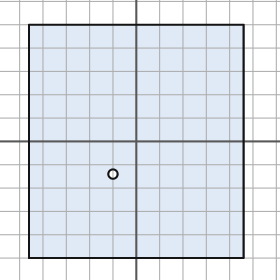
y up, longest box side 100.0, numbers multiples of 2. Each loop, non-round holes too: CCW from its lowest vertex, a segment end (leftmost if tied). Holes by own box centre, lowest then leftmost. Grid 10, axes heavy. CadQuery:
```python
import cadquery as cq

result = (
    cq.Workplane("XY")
    .moveTo(-46.0, -50.0)
    .lineTo(46.0, -50.0)
    .lineTo(46.0, 50.0)
    .lineTo(-46.0, 50.0)
    .close()
    .moveTo(-10.0, -14.0)
    .circle(2.0)
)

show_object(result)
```